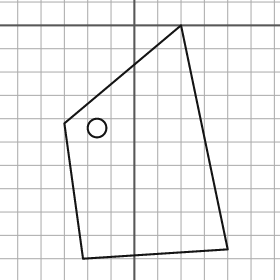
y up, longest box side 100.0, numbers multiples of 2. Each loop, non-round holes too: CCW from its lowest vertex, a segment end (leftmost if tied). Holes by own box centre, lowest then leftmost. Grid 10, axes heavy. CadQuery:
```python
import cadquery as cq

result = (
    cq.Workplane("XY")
    .moveTo(-22.0, -100.0)
    .lineTo(40.0, -96.0)
    .lineTo(20.0, 0.0)
    .lineTo(-30.0, -42.0)
    .close()
    .moveTo(-16.0, -44.0)
    .circle(4.0)
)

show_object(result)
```